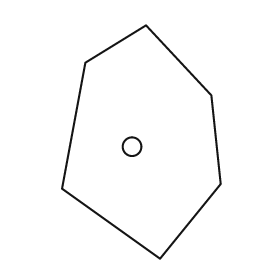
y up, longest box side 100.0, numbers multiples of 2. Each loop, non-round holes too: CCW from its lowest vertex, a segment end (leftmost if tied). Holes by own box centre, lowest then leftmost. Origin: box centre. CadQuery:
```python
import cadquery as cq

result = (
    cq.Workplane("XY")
    .moveTo(8.0, -50.0)
    .lineTo(34.0, -18.0)
    .lineTo(30.0, 20.0)
    .lineTo(2.0, 50.0)
    .lineTo(-24.0, 34.0)
    .lineTo(-34.0, -20.0)
    .close()
    .moveTo(-4.0, -2.0)
    .circle(4.0)
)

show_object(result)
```